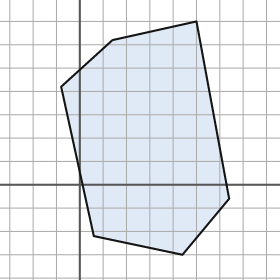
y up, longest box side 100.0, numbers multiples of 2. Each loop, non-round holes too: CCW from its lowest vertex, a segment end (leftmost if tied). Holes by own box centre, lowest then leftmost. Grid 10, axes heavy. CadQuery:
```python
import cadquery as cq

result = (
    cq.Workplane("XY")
    .moveTo(44.0, -30.0)
    .lineTo(64.0, -6.0)
    .lineTo(50.0, 70.0)
    .lineTo(14.0, 62.0)
    .lineTo(-8.0, 42.0)
    .lineTo(6.0, -22.0)
    .close()
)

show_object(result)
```